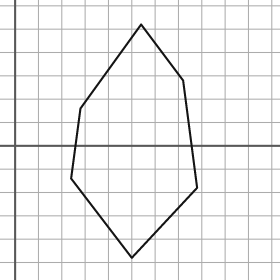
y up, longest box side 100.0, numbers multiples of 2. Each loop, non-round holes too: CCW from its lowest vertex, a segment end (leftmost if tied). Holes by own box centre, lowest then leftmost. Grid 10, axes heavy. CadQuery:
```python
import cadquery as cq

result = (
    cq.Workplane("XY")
    .moveTo(50.0, -48.0)
    .lineTo(78.0, -18.0)
    .lineTo(72.0, 28.0)
    .lineTo(54.0, 52.0)
    .lineTo(28.0, 16.0)
    .lineTo(24.0, -14.0)
    .close()
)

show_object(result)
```